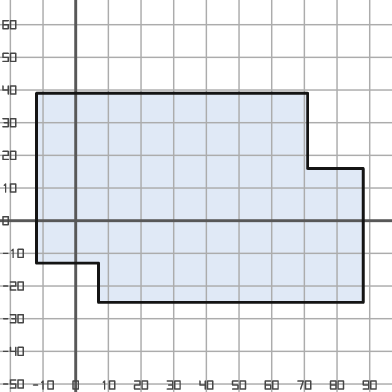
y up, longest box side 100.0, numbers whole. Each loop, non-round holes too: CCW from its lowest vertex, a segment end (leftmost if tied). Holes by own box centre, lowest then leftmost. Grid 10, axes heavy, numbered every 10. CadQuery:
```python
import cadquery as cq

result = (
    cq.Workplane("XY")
    .moveTo(7.0, -25.0)
    .lineTo(88.0, -25.0)
    .lineTo(88.0, 16.0)
    .lineTo(71.0, 16.0)
    .lineTo(71.0, 39.0)
    .lineTo(-12.0, 39.0)
    .lineTo(-12.0, -13.0)
    .lineTo(7.0, -13.0)
    .close()
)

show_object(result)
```